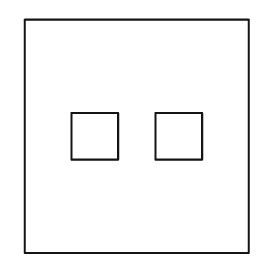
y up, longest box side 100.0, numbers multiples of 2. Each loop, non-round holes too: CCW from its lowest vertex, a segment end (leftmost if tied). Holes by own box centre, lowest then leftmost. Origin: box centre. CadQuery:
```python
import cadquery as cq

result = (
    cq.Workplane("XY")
    .moveTo(-48.0, -50.0)
    .lineTo(48.0, -50.0)
    .lineTo(48.0, 50.0)
    .lineTo(-48.0, 50.0)
    .close()
    .moveTo(-28.0, -10.0)
    .lineTo(-8.0, -10.0)
    .lineTo(-8.0, 10.0)
    .lineTo(-28.0, 10.0)
    .close()
    .moveTo(8.0, -10.0)
    .lineTo(28.0, -10.0)
    .lineTo(28.0, 10.0)
    .lineTo(8.0, 10.0)
    .close()
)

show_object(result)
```